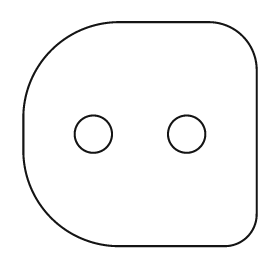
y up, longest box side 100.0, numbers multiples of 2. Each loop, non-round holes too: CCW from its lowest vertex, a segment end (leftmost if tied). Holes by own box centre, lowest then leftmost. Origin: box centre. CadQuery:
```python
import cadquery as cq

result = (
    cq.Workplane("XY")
    .moveTo(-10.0, -48.0)
    .lineTo(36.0, -48.0)
    .threePointArc((46.0, -44.0), (50.0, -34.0))
    .lineTo(50.0, 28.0)
    .threePointArc((44.0, 42.0), (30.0, 48.0))
    .lineTo(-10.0, 48.0)
    .threePointArc((-38.0, 36.0), (-50.0, 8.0))
    .lineTo(-50.0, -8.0)
    .threePointArc((-38.0, -36.0), (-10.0, -48.0))
    .close()
    .moveTo(-20.0, 0.0)
    .circle(8.0)
    .moveTo(20.0, 0.0)
    .circle(8.0)
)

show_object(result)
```